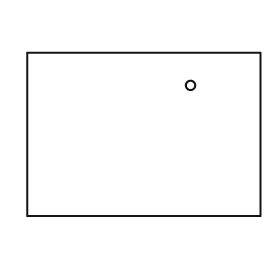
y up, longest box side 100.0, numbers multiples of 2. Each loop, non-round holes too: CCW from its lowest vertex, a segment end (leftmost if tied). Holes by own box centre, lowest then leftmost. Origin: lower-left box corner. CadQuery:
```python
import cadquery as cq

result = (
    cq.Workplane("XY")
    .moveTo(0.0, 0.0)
    .lineTo(100.0, 0.0)
    .lineTo(100.0, 70.0)
    .lineTo(0.0, 70.0)
    .close()
    .moveTo(70.0, 56.0)
    .circle(2.0)
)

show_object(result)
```